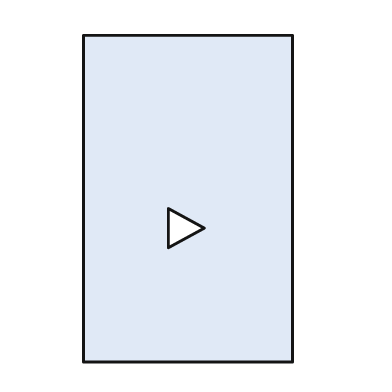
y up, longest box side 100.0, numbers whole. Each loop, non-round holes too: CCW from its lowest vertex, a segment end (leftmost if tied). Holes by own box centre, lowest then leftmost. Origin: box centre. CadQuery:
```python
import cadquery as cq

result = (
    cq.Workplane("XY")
    .moveTo(-32.0, -50.0)
    .lineTo(32.0, -50.0)
    .lineTo(32.0, 50.0)
    .lineTo(-32.0, 50.0)
    .close()
    .moveTo(-6.0, -15.0)
    .lineTo(5.0, -9.0)
    .lineTo(-6.0, -3.0)
    .close()
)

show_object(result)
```